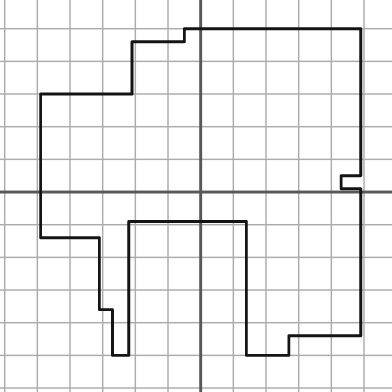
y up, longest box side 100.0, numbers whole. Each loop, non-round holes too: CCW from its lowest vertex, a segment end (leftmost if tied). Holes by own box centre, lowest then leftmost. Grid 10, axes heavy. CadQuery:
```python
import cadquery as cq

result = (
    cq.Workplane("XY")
    .moveTo(-27.0, -50.0)
    .lineTo(-22.0, -50.0)
    .lineTo(-22.0, -9.0)
    .lineTo(14.0, -9.0)
    .lineTo(14.0, -50.0)
    .lineTo(27.0, -50.0)
    .lineTo(27.0, -44.0)
    .lineTo(49.0, -44.0)
    .lineTo(49.0, 1.0)
    .lineTo(43.0, 1.0)
    .lineTo(43.0, 5.0)
    .lineTo(49.0, 5.0)
    .lineTo(49.0, 50.0)
    .lineTo(-5.0, 50.0)
    .lineTo(-5.0, 46.0)
    .lineTo(-21.0, 46.0)
    .lineTo(-21.0, 30.0)
    .lineTo(-49.0, 30.0)
    .lineTo(-49.0, -14.0)
    .lineTo(-31.0, -14.0)
    .lineTo(-31.0, -36.0)
    .lineTo(-27.0, -36.0)
    .close()
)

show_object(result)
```